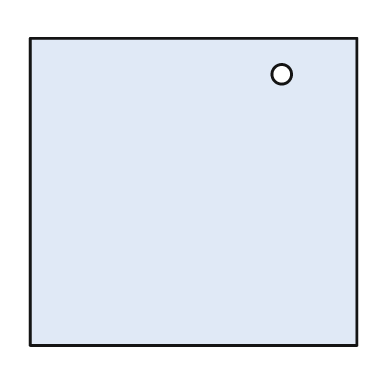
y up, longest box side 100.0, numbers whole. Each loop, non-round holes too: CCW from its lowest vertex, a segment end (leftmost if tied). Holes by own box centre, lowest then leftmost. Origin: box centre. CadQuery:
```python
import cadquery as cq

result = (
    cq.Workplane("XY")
    .moveTo(-50.0, -47.0)
    .lineTo(50.0, -47.0)
    .lineTo(50.0, 47.0)
    .lineTo(-50.0, 47.0)
    .close()
    .moveTo(27.0, 36.0)
    .circle(3.0)
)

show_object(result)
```